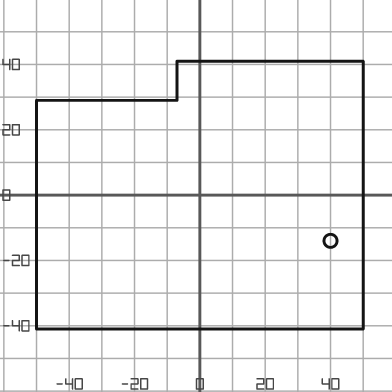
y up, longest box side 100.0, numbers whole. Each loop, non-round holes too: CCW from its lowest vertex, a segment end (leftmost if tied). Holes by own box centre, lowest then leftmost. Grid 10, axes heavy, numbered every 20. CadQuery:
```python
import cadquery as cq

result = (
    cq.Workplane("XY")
    .moveTo(-50.0, -41.0)
    .lineTo(50.0, -41.0)
    .lineTo(50.0, 41.0)
    .lineTo(-7.0, 41.0)
    .lineTo(-7.0, 29.0)
    .lineTo(-50.0, 29.0)
    .close()
    .moveTo(40.0, -14.0)
    .circle(2.0)
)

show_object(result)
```